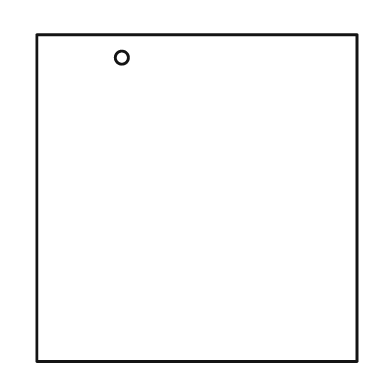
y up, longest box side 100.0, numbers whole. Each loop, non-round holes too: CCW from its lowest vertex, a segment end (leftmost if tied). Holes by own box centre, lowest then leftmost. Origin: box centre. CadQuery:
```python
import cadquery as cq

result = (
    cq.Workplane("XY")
    .moveTo(-49.0, -50.0)
    .lineTo(49.0, -50.0)
    .lineTo(49.0, 50.0)
    .lineTo(-49.0, 50.0)
    .close()
    .moveTo(-23.0, 43.0)
    .circle(2.0)
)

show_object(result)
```